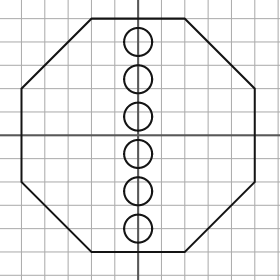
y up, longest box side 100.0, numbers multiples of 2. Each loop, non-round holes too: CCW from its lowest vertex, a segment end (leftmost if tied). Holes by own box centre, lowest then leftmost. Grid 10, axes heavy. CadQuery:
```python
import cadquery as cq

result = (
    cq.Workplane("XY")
    .moveTo(-20.0, -50.0)
    .lineTo(20.0, -50.0)
    .lineTo(50.0, -20.0)
    .lineTo(50.0, 20.0)
    .lineTo(20.0, 50.0)
    .lineTo(-20.0, 50.0)
    .lineTo(-50.0, 20.0)
    .lineTo(-50.0, -20.0)
    .close()
    .moveTo(0.0, -40.0)
    .circle(6.0)
    .moveTo(0.0, -24.0)
    .circle(6.0)
    .moveTo(0.0, -8.0)
    .circle(6.0)
    .moveTo(0.0, 8.0)
    .circle(6.0)
    .moveTo(0.0, 24.0)
    .circle(6.0)
    .moveTo(0.0, 40.0)
    .circle(6.0)
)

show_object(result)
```